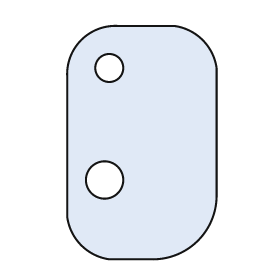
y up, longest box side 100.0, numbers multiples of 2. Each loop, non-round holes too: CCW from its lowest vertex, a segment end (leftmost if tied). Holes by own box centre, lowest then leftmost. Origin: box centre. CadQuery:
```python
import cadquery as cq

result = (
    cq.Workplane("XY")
    .moveTo(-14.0, -50.0)
    .lineTo(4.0, -50.0)
    .threePointArc((24.0, -42.0), (32.0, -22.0))
    .lineTo(32.0, 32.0)
    .threePointArc((26.0, 44.0), (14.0, 50.0))
    .lineTo(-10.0, 50.0)
    .threePointArc((-26.0, 44.0), (-32.0, 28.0))
    .lineTo(-32.0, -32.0)
    .threePointArc((-26.0, -44.0), (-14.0, -50.0))
    .close()
    .moveTo(-16.0, -16.0)
    .circle(8.0)
    .moveTo(-14.0, 32.0)
    .circle(6.0)
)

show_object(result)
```